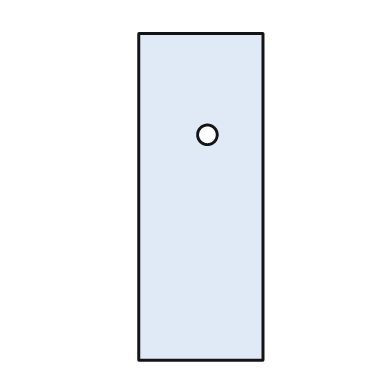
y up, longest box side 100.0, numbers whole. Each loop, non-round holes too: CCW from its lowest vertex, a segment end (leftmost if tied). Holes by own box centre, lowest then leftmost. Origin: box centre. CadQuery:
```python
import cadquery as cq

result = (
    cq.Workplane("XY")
    .moveTo(-19.0, -50.0)
    .lineTo(19.0, -50.0)
    .lineTo(19.0, 50.0)
    .lineTo(-19.0, 50.0)
    .close()
    .moveTo(2.0, 19.0)
    .circle(3.0)
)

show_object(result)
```